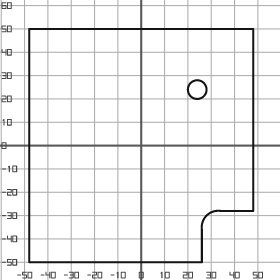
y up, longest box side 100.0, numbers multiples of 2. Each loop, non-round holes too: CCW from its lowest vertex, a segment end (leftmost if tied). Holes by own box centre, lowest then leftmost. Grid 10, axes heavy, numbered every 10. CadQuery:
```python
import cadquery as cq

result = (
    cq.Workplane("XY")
    .moveTo(-48.0, -50.0)
    .lineTo(26.0, -50.0)
    .lineTo(26.0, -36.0)
    .threePointArc((28.0, -30.0), (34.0, -28.0))
    .lineTo(48.0, -28.0)
    .lineTo(48.0, 50.0)
    .lineTo(-48.0, 50.0)
    .close()
    .moveTo(24.0, 24.0)
    .circle(4.0)
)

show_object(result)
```